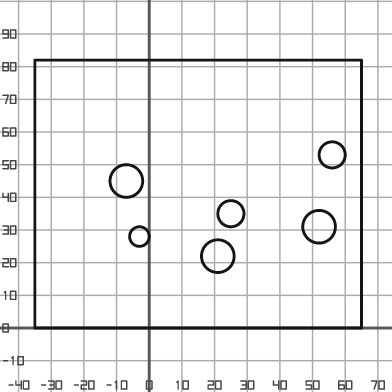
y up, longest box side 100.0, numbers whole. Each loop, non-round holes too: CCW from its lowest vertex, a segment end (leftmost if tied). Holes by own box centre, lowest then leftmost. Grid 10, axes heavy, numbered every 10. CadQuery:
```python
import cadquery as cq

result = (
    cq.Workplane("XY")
    .moveTo(-35.0, 0.0)
    .lineTo(65.0, 0.0)
    .lineTo(65.0, 82.0)
    .lineTo(-35.0, 82.0)
    .close()
    .moveTo(21.0, 22.0)
    .circle(5.0)
    .moveTo(-3.0, 28.0)
    .circle(3.0)
    .moveTo(52.0, 31.0)
    .circle(5.0)
    .moveTo(25.0, 35.0)
    .circle(4.0)
    .moveTo(-7.0, 45.0)
    .circle(5.0)
    .moveTo(56.0, 53.0)
    .circle(4.0)
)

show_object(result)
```